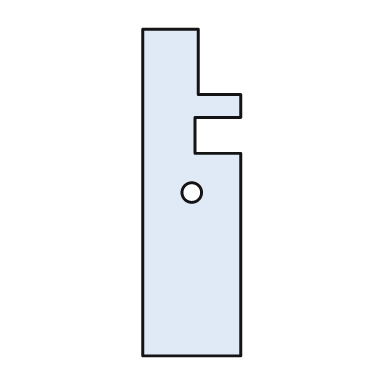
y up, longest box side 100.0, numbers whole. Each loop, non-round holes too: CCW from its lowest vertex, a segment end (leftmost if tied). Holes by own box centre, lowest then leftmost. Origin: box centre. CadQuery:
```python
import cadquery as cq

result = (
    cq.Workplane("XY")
    .moveTo(-15.0, -50.0)
    .lineTo(15.0, -50.0)
    .lineTo(15.0, 12.0)
    .lineTo(1.0, 12.0)
    .lineTo(1.0, 23.0)
    .lineTo(15.0, 23.0)
    .lineTo(15.0, 30.0)
    .lineTo(2.0, 30.0)
    .lineTo(2.0, 50.0)
    .lineTo(-15.0, 50.0)
    .close()
    .moveTo(0.0, 0.0)
    .circle(3.0)
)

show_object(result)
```